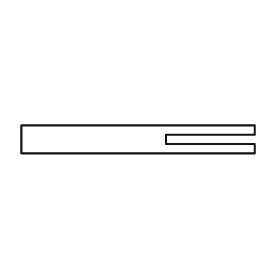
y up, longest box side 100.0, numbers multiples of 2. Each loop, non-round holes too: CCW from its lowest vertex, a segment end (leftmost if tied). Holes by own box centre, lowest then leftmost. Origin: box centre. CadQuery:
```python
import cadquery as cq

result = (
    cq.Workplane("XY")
    .moveTo(-50.0, -6.0)
    .lineTo(50.0, -6.0)
    .lineTo(50.0, -2.0)
    .lineTo(12.0, -2.0)
    .lineTo(12.0, 2.0)
    .lineTo(50.0, 2.0)
    .lineTo(50.0, 6.0)
    .lineTo(-50.0, 6.0)
    .close()
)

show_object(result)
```